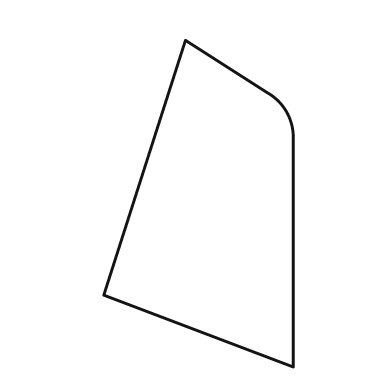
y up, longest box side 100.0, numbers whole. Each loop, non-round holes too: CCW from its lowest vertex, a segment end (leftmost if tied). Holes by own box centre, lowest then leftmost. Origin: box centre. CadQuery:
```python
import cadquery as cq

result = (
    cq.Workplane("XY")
    .moveTo(29.0, -50.0)
    .lineTo(29.0, 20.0)
    .threePointArc((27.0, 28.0), (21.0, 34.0))
    .lineTo(-4.0, 50.0)
    .lineTo(-29.0, -28.0)
    .close()
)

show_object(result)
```